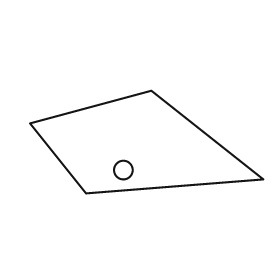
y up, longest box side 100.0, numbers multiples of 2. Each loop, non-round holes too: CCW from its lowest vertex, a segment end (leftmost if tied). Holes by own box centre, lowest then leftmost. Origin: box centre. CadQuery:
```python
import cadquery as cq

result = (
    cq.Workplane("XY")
    .moveTo(-26.0, -22.0)
    .lineTo(50.0, -16.0)
    .lineTo(2.0, 22.0)
    .lineTo(-50.0, 8.0)
    .close()
    .moveTo(-10.0, -12.0)
    .circle(4.0)
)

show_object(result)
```